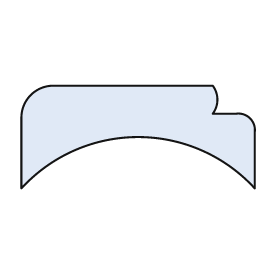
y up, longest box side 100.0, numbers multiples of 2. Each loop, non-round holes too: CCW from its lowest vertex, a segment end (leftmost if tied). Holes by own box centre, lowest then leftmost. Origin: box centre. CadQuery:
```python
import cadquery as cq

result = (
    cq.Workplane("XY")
    .moveTo(-50.0, -22.0)
    .threePointArc((0.0, 0.0), (50.0, -22.0))
    .lineTo(50.0, 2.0)
    .threePointArc((48.0, 8.0), (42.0, 10.0))
    .lineTo(32.0, 10.0)
    .threePointArc((34.0, 16.0), (32.0, 22.0))
    .lineTo(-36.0, 22.0)
    .threePointArc((-46.0, 18.0), (-50.0, 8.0))
    .close()
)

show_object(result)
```